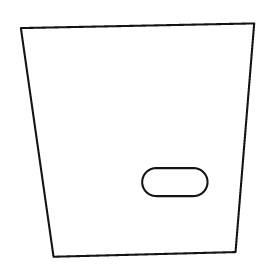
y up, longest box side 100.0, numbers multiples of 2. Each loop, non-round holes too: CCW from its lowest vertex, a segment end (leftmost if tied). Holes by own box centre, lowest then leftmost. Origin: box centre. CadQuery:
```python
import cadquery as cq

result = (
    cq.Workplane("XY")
    .moveTo(-36.0, -50.0)
    .lineTo(42.0, -48.0)
    .lineTo(50.0, 50.0)
    .lineTo(-50.0, 48.0)
    .close()
    .moveTo(8.0, -24.0)
    .lineTo(24.0, -24.0)
    .threePointArc((30.0, -18.0), (24.0, -12.0))
    .lineTo(8.0, -12.0)
    .threePointArc((2.0, -18.0), (8.0, -24.0))
    .close()
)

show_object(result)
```